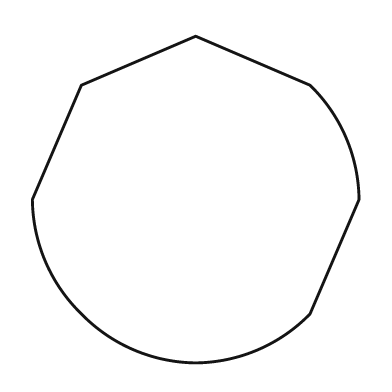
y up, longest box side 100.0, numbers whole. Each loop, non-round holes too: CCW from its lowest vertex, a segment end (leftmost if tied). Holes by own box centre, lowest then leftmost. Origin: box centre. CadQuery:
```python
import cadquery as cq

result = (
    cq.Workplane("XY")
    .moveTo(0.0, -50.0)
    .threePointArc((19.0, -46.0), (35.0, -35.0))
    .lineTo(50.0, 0.0)
    .threePointArc((46.0, 19.0), (35.0, 35.0))
    .lineTo(0.0, 50.0)
    .lineTo(-35.0, 35.0)
    .lineTo(-50.0, 0.0)
    .threePointArc((-46.0, -19.0), (-35.0, -35.0))
    .threePointArc((-19.0, -46.0), (0.0, -50.0))
    .close()
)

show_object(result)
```